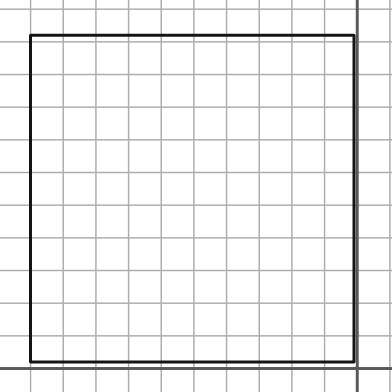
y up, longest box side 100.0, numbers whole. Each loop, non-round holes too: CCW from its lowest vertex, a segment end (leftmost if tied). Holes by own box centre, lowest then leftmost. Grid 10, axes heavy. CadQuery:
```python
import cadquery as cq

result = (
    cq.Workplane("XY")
    .moveTo(-100.0, 2.0)
    .lineTo(-1.0, 2.0)
    .lineTo(-1.0, 102.0)
    .lineTo(-100.0, 102.0)
    .close()
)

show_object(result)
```